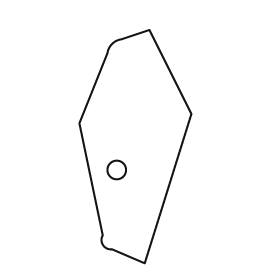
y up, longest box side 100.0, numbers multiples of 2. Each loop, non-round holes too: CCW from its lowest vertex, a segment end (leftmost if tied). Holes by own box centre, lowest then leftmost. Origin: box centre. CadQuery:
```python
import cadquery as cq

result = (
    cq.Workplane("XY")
    .moveTo(4.0, -50.0)
    .lineTo(24.0, 14.0)
    .lineTo(6.0, 50.0)
    .lineTo(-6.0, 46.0)
    .threePointArc((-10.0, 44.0), (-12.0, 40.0))
    .lineTo(-24.0, 10.0)
    .lineTo(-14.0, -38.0)
    .threePointArc((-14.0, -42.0), (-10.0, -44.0))
    .close()
    .moveTo(-8.0, -10.0)
    .circle(4.0)
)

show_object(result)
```